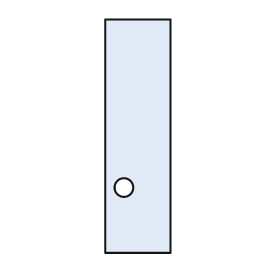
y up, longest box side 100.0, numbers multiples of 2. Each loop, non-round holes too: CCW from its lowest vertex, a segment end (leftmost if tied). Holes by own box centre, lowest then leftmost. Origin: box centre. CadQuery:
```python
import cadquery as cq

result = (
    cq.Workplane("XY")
    .moveTo(-14.0, -50.0)
    .lineTo(14.0, -50.0)
    .lineTo(14.0, 50.0)
    .lineTo(-14.0, 50.0)
    .close()
    .moveTo(-6.0, -22.0)
    .circle(4.0)
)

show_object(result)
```